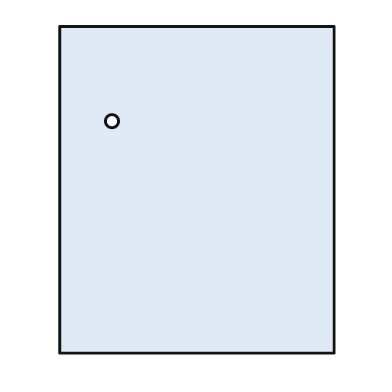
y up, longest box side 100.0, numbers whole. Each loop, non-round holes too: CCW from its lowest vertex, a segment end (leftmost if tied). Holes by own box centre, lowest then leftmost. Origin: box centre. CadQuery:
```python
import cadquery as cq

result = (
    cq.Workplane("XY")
    .moveTo(-42.0, -50.0)
    .lineTo(42.0, -50.0)
    .lineTo(42.0, 50.0)
    .lineTo(-42.0, 50.0)
    .close()
    .moveTo(-26.0, 21.0)
    .circle(2.0)
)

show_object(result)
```